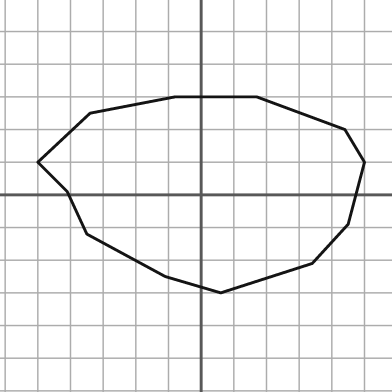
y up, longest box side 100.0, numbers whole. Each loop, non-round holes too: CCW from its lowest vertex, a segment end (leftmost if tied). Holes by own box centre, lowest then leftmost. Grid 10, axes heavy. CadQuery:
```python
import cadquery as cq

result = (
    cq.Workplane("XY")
    .moveTo(6.0, -30.0)
    .lineTo(34.0, -21.0)
    .lineTo(45.0, -9.0)
    .lineTo(50.0, 10.0)
    .lineTo(44.0, 20.0)
    .lineTo(17.0, 30.0)
    .lineTo(-8.0, 30.0)
    .lineTo(-34.0, 25.0)
    .lineTo(-50.0, 10.0)
    .lineTo(-41.0, 1.0)
    .lineTo(-35.0, -12.0)
    .lineTo(-11.0, -25.0)
    .close()
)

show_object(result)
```